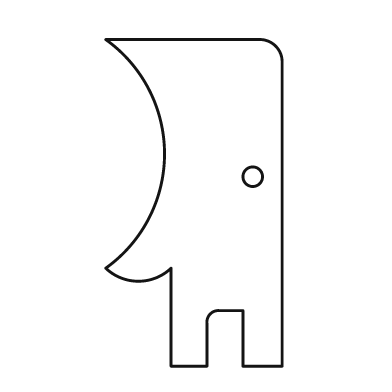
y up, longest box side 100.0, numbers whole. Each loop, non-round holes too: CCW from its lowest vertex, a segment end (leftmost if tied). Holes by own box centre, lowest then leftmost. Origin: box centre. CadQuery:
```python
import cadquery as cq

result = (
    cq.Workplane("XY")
    .moveTo(-7.0, -50.0)
    .lineTo(4.0, -50.0)
    .lineTo(4.0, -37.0)
    .threePointArc((5.0, -34.0), (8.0, -33.0))
    .lineTo(15.0, -33.0)
    .lineTo(15.0, -50.0)
    .lineTo(27.0, -50.0)
    .lineTo(27.0, 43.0)
    .threePointArc((25.0, 48.0), (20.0, 50.0))
    .lineTo(-27.0, 50.0)
    .threePointArc((-9.0, 15.0), (-27.0, -20.0))
    .threePointArc((-17.0, -24.0), (-7.0, -20.0))
    .close()
    .moveTo(18.0, 8.0)
    .circle(3.0)
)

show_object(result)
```